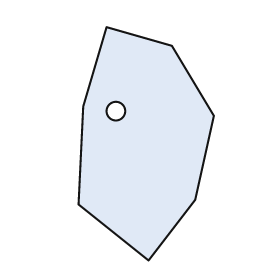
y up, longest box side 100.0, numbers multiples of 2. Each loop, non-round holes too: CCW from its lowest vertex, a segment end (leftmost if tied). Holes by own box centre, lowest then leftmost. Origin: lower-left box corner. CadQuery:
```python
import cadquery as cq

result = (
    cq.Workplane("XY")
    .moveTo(30.0, 0.0)
    .lineTo(50.0, 26.0)
    .lineTo(58.0, 62.0)
    .lineTo(40.0, 92.0)
    .lineTo(12.0, 100.0)
    .lineTo(2.0, 66.0)
    .lineTo(0.0, 24.0)
    .close()
    .moveTo(16.0, 64.0)
    .circle(4.0)
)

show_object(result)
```